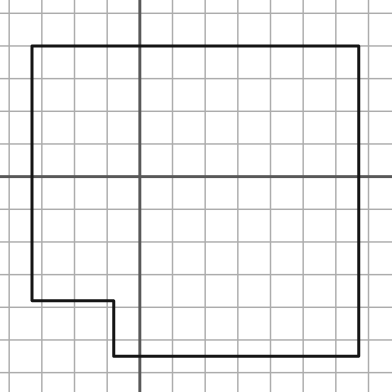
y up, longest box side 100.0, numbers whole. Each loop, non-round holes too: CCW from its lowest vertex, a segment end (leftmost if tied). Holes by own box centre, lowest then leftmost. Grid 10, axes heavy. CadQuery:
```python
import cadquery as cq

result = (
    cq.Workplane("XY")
    .moveTo(-8.0, -55.0)
    .lineTo(67.0, -55.0)
    .lineTo(67.0, 40.0)
    .lineTo(-33.0, 40.0)
    .lineTo(-33.0, -38.0)
    .lineTo(-8.0, -38.0)
    .close()
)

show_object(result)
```